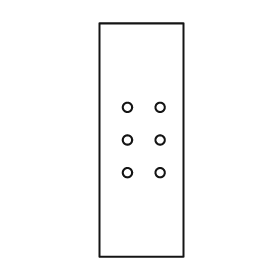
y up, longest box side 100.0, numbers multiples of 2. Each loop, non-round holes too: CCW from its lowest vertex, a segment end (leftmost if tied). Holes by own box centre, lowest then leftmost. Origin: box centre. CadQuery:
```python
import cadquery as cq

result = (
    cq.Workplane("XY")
    .moveTo(-18.0, -50.0)
    .lineTo(18.0, -50.0)
    .lineTo(18.0, 50.0)
    .lineTo(-18.0, 50.0)
    .close()
    .moveTo(-6.0, -14.0)
    .circle(2.0)
    .moveTo(8.0, -14.0)
    .circle(2.0)
    .moveTo(-6.0, 0.0)
    .circle(2.0)
    .moveTo(8.0, 0.0)
    .circle(2.0)
    .moveTo(-6.0, 14.0)
    .circle(2.0)
    .moveTo(8.0, 14.0)
    .circle(2.0)
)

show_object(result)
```